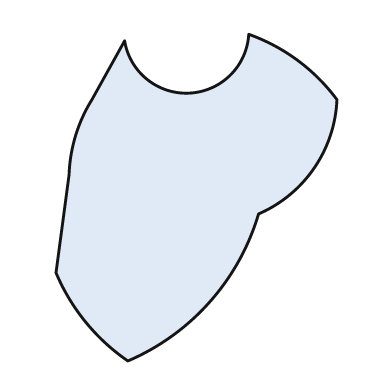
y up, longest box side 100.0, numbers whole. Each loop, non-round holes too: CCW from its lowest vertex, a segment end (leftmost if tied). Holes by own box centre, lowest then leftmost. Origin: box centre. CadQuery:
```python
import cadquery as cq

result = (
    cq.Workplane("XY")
    .moveTo(-21.0, -50.0)
    .threePointArc((4.0, -32.0), (19.0, -5.0))
    .threePointArc((36.0, 9.0), (43.0, 30.0))
    .threePointArc((31.0, 42.0), (16.0, 50.0))
    .threePointArc((-2.0, 32.0), (-22.0, 48.0))
    .lineTo(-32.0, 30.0)
    .threePointArc((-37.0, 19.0), (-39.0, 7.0))
    .lineTo(-43.0, -23.0)
    .threePointArc((-34.0, -38.0), (-21.0, -50.0))
    .close()
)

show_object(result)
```